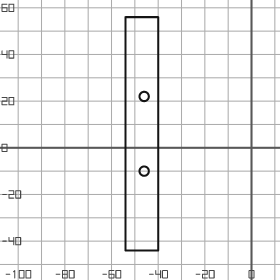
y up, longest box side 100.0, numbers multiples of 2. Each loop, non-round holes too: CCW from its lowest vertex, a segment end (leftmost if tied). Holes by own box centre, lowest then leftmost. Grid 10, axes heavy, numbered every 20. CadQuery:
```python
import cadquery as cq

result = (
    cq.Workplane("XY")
    .moveTo(-54.0, -44.0)
    .lineTo(-40.0, -44.0)
    .lineTo(-40.0, 56.0)
    .lineTo(-54.0, 56.0)
    .close()
    .moveTo(-46.0, -10.0)
    .circle(2.0)
    .moveTo(-46.0, 22.0)
    .circle(2.0)
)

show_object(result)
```